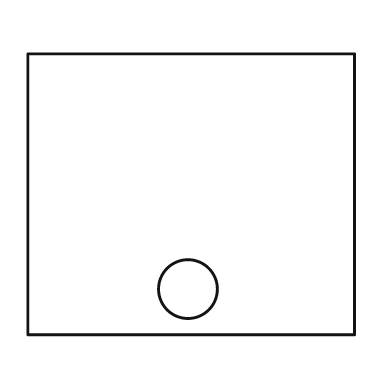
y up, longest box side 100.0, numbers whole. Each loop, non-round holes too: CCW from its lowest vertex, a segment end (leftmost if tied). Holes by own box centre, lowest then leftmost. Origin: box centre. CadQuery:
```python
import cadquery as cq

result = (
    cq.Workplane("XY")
    .moveTo(-50.0, -43.0)
    .lineTo(50.0, -43.0)
    .lineTo(50.0, 43.0)
    .lineTo(-50.0, 43.0)
    .close()
    .moveTo(-1.0, -29.0)
    .circle(9.0)
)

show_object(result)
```